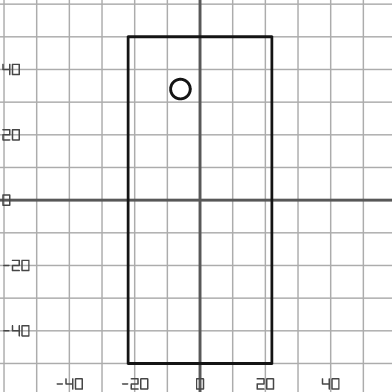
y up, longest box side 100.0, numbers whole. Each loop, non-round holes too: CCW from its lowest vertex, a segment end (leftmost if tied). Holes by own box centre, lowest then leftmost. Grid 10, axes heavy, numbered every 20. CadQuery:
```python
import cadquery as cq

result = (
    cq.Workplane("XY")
    .moveTo(-22.0, -50.0)
    .lineTo(22.0, -50.0)
    .lineTo(22.0, 50.0)
    .lineTo(-22.0, 50.0)
    .close()
    .moveTo(-6.0, 34.0)
    .circle(3.0)
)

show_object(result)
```